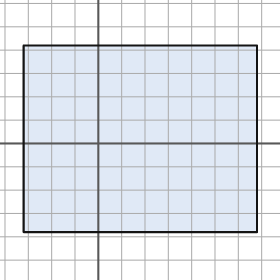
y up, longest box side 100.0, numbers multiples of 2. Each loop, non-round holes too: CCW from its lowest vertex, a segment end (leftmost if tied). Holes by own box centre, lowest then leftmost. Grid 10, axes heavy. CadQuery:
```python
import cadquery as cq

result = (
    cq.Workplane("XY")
    .moveTo(-32.0, -38.0)
    .lineTo(68.0, -38.0)
    .lineTo(68.0, 42.0)
    .lineTo(-32.0, 42.0)
    .close()
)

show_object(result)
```